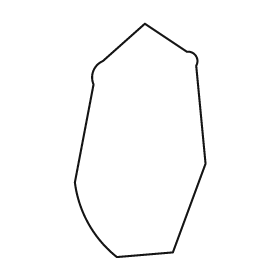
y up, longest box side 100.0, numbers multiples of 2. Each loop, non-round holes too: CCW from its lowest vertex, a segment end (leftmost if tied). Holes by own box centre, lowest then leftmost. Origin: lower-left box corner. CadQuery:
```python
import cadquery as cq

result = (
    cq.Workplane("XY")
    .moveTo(18.0, 0.0)
    .lineTo(42.0, 2.0)
    .lineTo(56.0, 40.0)
    .lineTo(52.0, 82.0)
    .threePointArc((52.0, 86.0), (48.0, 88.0))
    .lineTo(30.0, 100.0)
    .lineTo(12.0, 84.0)
    .threePointArc((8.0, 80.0), (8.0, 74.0))
    .lineTo(0.0, 32.0)
    .threePointArc((6.0, 14.0), (18.0, 0.0))
    .close()
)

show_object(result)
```